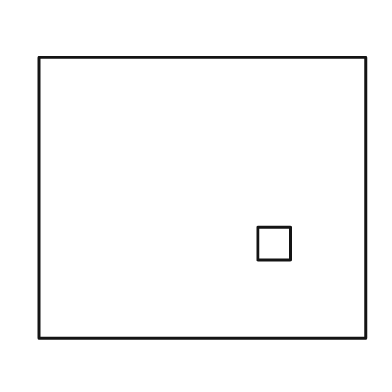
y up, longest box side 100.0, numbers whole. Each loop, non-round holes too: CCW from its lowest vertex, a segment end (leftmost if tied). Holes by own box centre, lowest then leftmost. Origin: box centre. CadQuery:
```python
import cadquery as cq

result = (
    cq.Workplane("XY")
    .moveTo(-50.0, -43.0)
    .lineTo(50.0, -43.0)
    .lineTo(50.0, 43.0)
    .lineTo(-50.0, 43.0)
    .close()
    .moveTo(17.0, -19.0)
    .lineTo(27.0, -19.0)
    .lineTo(27.0, -9.0)
    .lineTo(17.0, -9.0)
    .close()
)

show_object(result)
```